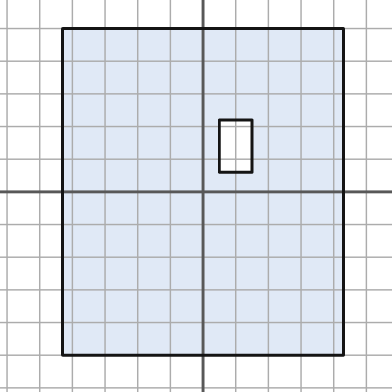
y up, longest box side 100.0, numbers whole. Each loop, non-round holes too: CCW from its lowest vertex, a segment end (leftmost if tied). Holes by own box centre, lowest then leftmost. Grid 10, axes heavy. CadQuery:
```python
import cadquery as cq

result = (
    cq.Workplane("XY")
    .moveTo(-43.0, -50.0)
    .lineTo(43.0, -50.0)
    .lineTo(43.0, 50.0)
    .lineTo(-43.0, 50.0)
    .close()
    .moveTo(5.0, 6.0)
    .lineTo(15.0, 6.0)
    .lineTo(15.0, 22.0)
    .lineTo(5.0, 22.0)
    .close()
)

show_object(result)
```